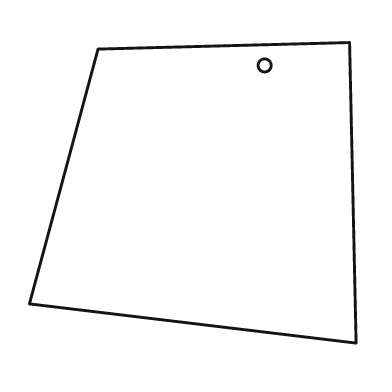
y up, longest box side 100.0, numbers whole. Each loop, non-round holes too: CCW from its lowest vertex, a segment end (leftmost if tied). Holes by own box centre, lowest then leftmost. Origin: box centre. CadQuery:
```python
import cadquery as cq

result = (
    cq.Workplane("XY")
    .moveTo(50.0, -46.0)
    .lineTo(48.0, 46.0)
    .lineTo(-29.0, 44.0)
    .lineTo(-50.0, -34.0)
    .close()
    .moveTo(22.0, 39.0)
    .circle(2.0)
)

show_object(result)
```